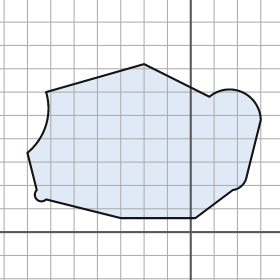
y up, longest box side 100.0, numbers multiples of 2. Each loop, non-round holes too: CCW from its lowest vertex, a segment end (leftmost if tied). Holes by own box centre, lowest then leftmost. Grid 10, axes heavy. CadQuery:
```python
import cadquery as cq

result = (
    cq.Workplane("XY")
    .moveTo(-30.0, 6.0)
    .lineTo(2.0, 6.0)
    .lineTo(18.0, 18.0)
    .threePointArc((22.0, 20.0), (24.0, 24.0))
    .lineTo(30.0, 48.0)
    .threePointArc((22.0, 60.0), (8.0, 58.0))
    .lineTo(-20.0, 72.0)
    .lineTo(-62.0, 60.0)
    .threePointArc((-62.0, 46.0), (-70.0, 34.0))
    .lineTo(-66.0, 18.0)
    .threePointArc((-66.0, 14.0), (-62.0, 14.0))
    .close()
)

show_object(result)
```